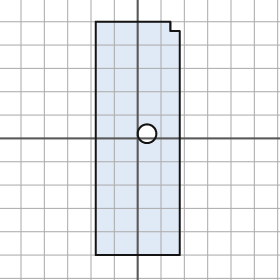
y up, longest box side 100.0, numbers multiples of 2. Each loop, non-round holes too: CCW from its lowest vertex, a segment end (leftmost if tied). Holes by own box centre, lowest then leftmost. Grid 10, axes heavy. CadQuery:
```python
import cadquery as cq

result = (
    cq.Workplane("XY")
    .moveTo(-18.0, -50.0)
    .lineTo(18.0, -50.0)
    .lineTo(18.0, 46.0)
    .lineTo(14.0, 46.0)
    .lineTo(14.0, 50.0)
    .lineTo(-18.0, 50.0)
    .close()
    .moveTo(4.0, 2.0)
    .circle(4.0)
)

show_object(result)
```